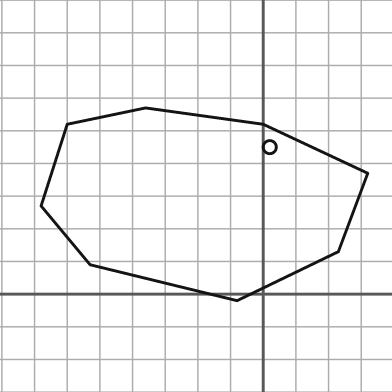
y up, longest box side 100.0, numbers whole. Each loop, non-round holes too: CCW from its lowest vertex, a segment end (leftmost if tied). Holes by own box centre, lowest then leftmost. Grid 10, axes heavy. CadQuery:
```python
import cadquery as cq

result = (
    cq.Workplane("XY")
    .moveTo(-8.0, -2.0)
    .lineTo(23.0, 13.0)
    .lineTo(32.0, 37.0)
    .lineTo(0.0, 52.0)
    .lineTo(-36.0, 57.0)
    .lineTo(-60.0, 52.0)
    .lineTo(-68.0, 27.0)
    .lineTo(-53.0, 9.0)
    .close()
    .moveTo(2.0, 45.0)
    .circle(2.0)
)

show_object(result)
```